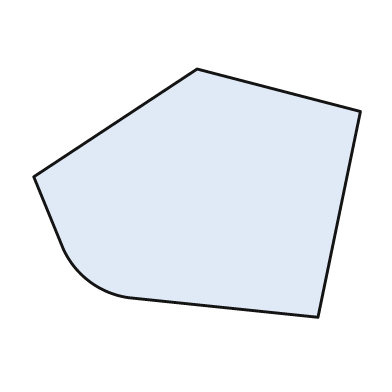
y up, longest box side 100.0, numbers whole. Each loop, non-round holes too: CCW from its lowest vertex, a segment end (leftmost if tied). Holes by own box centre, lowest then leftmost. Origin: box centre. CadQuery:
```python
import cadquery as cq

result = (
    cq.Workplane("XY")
    .moveTo(37.0, -38.0)
    .lineTo(50.0, 25.0)
    .lineTo(0.0, 38.0)
    .lineTo(-50.0, 5.0)
    .lineTo(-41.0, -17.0)
    .threePointArc((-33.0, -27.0), (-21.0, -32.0))
    .close()
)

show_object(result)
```